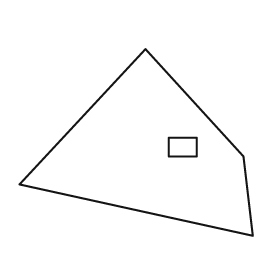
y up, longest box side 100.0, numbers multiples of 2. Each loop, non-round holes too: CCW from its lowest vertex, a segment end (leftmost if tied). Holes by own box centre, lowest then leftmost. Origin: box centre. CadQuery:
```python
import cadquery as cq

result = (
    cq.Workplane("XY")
    .moveTo(50.0, -40.0)
    .lineTo(46.0, -6.0)
    .lineTo(4.0, 40.0)
    .lineTo(-50.0, -18.0)
    .close()
    .moveTo(14.0, -6.0)
    .lineTo(26.0, -6.0)
    .lineTo(26.0, 2.0)
    .lineTo(14.0, 2.0)
    .close()
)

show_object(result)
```